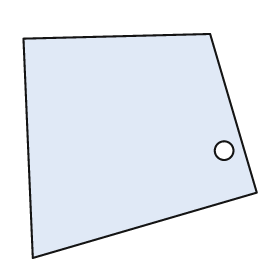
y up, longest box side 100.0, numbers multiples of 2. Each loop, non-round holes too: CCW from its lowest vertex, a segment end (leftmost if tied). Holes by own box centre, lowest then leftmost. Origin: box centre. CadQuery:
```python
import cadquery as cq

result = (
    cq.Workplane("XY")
    .moveTo(-46.0, -48.0)
    .lineTo(50.0, -20.0)
    .lineTo(30.0, 48.0)
    .lineTo(-50.0, 46.0)
    .close()
    .moveTo(36.0, -2.0)
    .circle(4.0)
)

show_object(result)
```